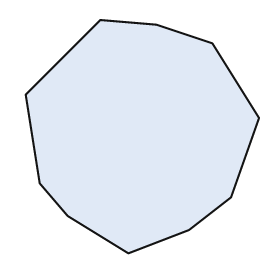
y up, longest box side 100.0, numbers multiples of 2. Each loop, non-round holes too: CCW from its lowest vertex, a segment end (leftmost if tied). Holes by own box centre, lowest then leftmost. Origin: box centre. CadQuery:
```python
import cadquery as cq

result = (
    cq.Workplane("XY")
    .moveTo(-6.0, -50.0)
    .lineTo(20.0, -40.0)
    .lineTo(38.0, -26.0)
    .lineTo(50.0, 8.0)
    .lineTo(30.0, 40.0)
    .lineTo(6.0, 48.0)
    .lineTo(-18.0, 50.0)
    .lineTo(-50.0, 18.0)
    .lineTo(-44.0, -20.0)
    .lineTo(-32.0, -34.0)
    .close()
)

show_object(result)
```